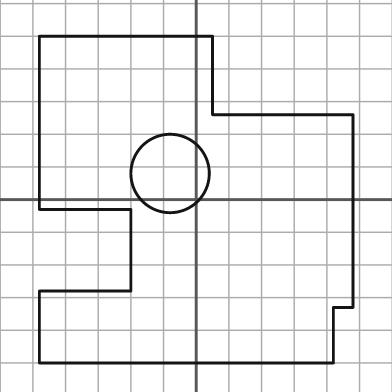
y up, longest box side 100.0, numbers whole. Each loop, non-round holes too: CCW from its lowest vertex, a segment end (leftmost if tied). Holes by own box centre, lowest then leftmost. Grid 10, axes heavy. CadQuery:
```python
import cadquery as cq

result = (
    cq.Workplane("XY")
    .moveTo(-48.0, -50.0)
    .lineTo(42.0, -50.0)
    .lineTo(42.0, -33.0)
    .lineTo(48.0, -33.0)
    .lineTo(48.0, 26.0)
    .lineTo(5.0, 26.0)
    .lineTo(5.0, 50.0)
    .lineTo(-48.0, 50.0)
    .lineTo(-48.0, -3.0)
    .lineTo(-20.0, -3.0)
    .lineTo(-20.0, -28.0)
    .lineTo(-48.0, -28.0)
    .close()
    .moveTo(-8.0, 8.0)
    .circle(12.0)
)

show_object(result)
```